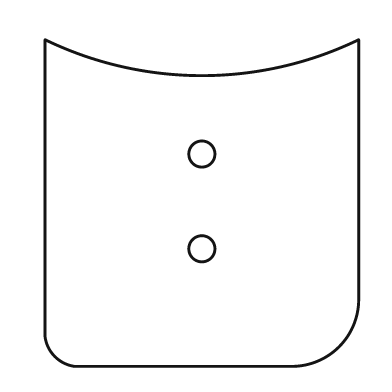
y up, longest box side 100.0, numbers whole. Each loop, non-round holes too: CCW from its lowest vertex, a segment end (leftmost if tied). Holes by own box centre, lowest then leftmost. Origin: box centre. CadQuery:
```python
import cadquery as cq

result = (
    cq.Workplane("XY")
    .moveTo(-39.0, -50.0)
    .lineTo(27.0, -50.0)
    .threePointArc((42.0, -44.0), (48.0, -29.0))
    .lineTo(48.0, 50.0)
    .threePointArc((0.0, 39.0), (-48.0, 50.0))
    .lineTo(-48.0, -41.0)
    .threePointArc((-45.0, -47.0), (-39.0, -50.0))
    .close()
    .moveTo(0.0, -14.0)
    .circle(4.0)
    .moveTo(0.0, 15.0)
    .circle(4.0)
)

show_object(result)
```